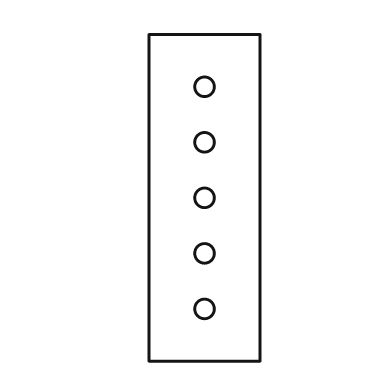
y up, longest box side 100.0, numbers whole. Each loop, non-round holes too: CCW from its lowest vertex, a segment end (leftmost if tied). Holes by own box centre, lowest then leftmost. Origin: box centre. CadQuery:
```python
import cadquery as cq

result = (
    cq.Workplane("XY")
    .moveTo(-17.0, -50.0)
    .lineTo(17.0, -50.0)
    .lineTo(17.0, 50.0)
    .lineTo(-17.0, 50.0)
    .close()
    .moveTo(0.0, -34.0)
    .circle(3.0)
    .moveTo(0.0, -17.0)
    .circle(3.0)
    .moveTo(0.0, 0.0)
    .circle(3.0)
    .moveTo(0.0, 17.0)
    .circle(3.0)
    .moveTo(0.0, 34.0)
    .circle(3.0)
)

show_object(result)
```